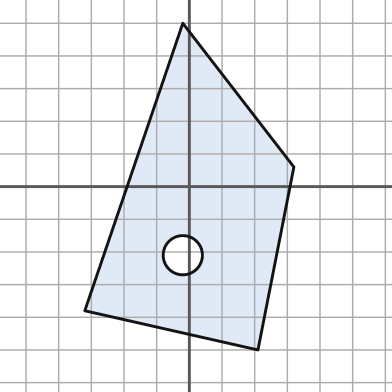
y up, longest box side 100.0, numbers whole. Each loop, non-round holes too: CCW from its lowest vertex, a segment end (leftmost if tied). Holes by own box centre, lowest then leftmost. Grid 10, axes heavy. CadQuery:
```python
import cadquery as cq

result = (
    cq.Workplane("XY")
    .moveTo(21.0, -50.0)
    .lineTo(32.0, 6.0)
    .lineTo(-2.0, 50.0)
    .lineTo(-32.0, -38.0)
    .close()
    .moveTo(-2.0, -21.0)
    .circle(6.0)
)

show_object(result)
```